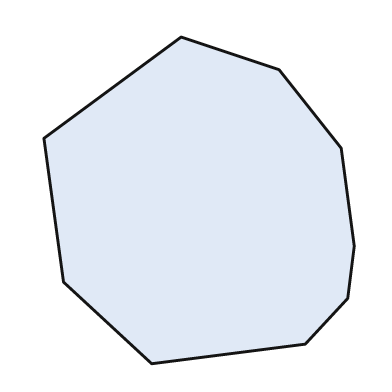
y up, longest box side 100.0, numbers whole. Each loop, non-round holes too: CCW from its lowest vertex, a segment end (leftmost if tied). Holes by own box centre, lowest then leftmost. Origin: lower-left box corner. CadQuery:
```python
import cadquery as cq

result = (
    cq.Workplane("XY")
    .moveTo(33.0, 0.0)
    .lineTo(80.0, 6.0)
    .lineTo(93.0, 20.0)
    .lineTo(95.0, 36.0)
    .lineTo(91.0, 66.0)
    .lineTo(72.0, 90.0)
    .lineTo(42.0, 100.0)
    .lineTo(0.0, 69.0)
    .lineTo(6.0, 25.0)
    .close()
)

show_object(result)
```